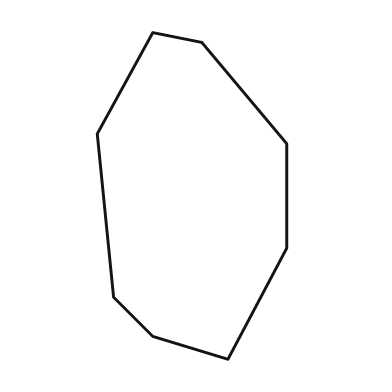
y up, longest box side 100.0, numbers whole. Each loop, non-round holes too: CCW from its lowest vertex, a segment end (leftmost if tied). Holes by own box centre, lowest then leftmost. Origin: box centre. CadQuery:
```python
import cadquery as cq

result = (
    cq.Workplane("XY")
    .moveTo(11.0, -50.0)
    .lineTo(29.0, -16.0)
    .lineTo(29.0, 16.0)
    .lineTo(3.0, 47.0)
    .lineTo(-12.0, 50.0)
    .lineTo(-29.0, 19.0)
    .lineTo(-24.0, -31.0)
    .lineTo(-12.0, -43.0)
    .close()
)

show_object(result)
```